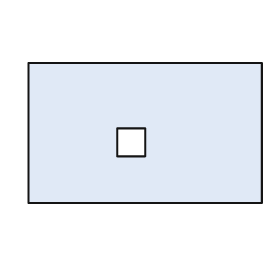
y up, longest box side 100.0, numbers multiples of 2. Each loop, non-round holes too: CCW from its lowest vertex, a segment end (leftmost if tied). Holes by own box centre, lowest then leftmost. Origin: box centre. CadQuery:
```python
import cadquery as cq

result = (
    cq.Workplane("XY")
    .moveTo(-50.0, -30.0)
    .lineTo(50.0, -30.0)
    .lineTo(50.0, 30.0)
    .lineTo(-50.0, 30.0)
    .close()
    .moveTo(-12.0, -10.0)
    .lineTo(0.0, -10.0)
    .lineTo(0.0, 2.0)
    .lineTo(-12.0, 2.0)
    .close()
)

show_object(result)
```